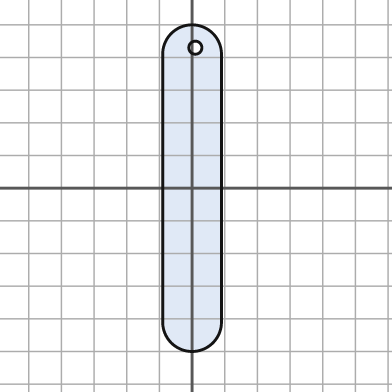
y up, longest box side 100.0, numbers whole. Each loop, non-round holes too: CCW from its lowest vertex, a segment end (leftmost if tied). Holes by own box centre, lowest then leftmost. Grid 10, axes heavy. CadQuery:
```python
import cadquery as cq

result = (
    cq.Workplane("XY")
    .moveTo(-9.0, -41.0)
    .threePointArc((0.0, -50.0), (9.0, -41.0))
    .lineTo(9.0, 41.0)
    .threePointArc((0.0, 50.0), (-9.0, 41.0))
    .close()
    .moveTo(1.0, 43.0)
    .circle(2.0)
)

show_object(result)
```